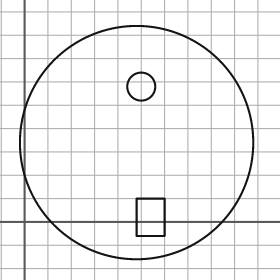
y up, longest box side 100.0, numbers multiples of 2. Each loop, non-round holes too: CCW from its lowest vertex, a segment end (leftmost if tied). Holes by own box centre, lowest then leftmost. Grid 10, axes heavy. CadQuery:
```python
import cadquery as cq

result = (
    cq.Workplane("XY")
    .moveTo(48.0, 34.0)
    .circle(50.0)
    .moveTo(48.0, -6.0)
    .lineTo(60.0, -6.0)
    .lineTo(60.0, 10.0)
    .lineTo(48.0, 10.0)
    .close()
    .moveTo(50.0, 58.0)
    .circle(6.0)
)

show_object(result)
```